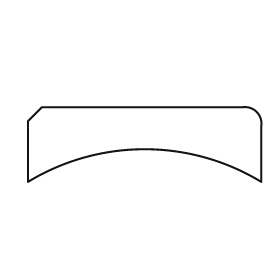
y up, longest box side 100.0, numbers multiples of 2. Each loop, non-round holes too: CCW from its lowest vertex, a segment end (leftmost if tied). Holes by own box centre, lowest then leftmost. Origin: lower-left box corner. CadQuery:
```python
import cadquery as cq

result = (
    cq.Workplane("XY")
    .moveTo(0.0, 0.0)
    .threePointArc((50.0, 14.0), (100.0, 0.0))
    .lineTo(100.0, 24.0)
    .threePointArc((98.0, 30.0), (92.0, 32.0))
    .lineTo(6.0, 32.0)
    .lineTo(0.0, 26.0)
    .close()
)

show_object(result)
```